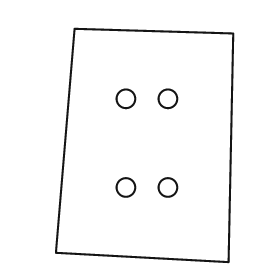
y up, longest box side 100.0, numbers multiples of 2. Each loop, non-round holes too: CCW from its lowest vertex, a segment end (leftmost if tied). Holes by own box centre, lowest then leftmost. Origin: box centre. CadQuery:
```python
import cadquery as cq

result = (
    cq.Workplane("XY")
    .moveTo(36.0, -50.0)
    .lineTo(38.0, 48.0)
    .lineTo(-30.0, 50.0)
    .lineTo(-38.0, -46.0)
    .close()
    .moveTo(-8.0, -18.0)
    .circle(4.0)
    .moveTo(10.0, -18.0)
    .circle(4.0)
    .moveTo(-8.0, 20.0)
    .circle(4.0)
    .moveTo(10.0, 20.0)
    .circle(4.0)
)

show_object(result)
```